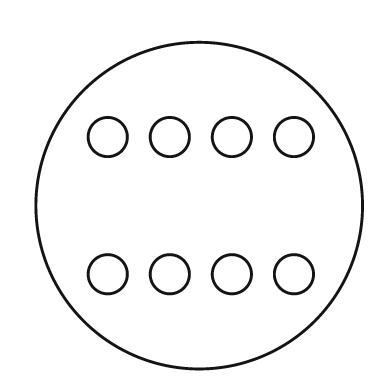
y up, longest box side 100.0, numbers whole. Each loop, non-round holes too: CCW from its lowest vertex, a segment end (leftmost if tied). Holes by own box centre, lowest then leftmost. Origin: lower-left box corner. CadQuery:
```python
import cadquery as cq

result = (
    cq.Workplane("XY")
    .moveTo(50.0, 50.0)
    .circle(50.0)
    .moveTo(22.0, 29.0)
    .circle(6.0)
    .moveTo(41.0, 29.0)
    .circle(6.0)
    .moveTo(60.0, 29.0)
    .circle(6.0)
    .moveTo(79.0, 29.0)
    .circle(6.0)
    .moveTo(22.0, 71.0)
    .circle(6.0)
    .moveTo(41.0, 71.0)
    .circle(6.0)
    .moveTo(60.0, 71.0)
    .circle(6.0)
    .moveTo(79.0, 71.0)
    .circle(6.0)
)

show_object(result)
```